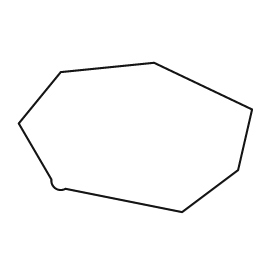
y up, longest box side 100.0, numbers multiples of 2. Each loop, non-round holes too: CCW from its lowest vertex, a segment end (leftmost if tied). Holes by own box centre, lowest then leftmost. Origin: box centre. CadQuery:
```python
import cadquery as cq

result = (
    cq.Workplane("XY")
    .moveTo(20.0, -32.0)
    .lineTo(44.0, -14.0)
    .lineTo(50.0, 12.0)
    .lineTo(8.0, 32.0)
    .lineTo(-32.0, 28.0)
    .lineTo(-50.0, 6.0)
    .lineTo(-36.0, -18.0)
    .threePointArc((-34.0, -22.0), (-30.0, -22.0))
    .close()
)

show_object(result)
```